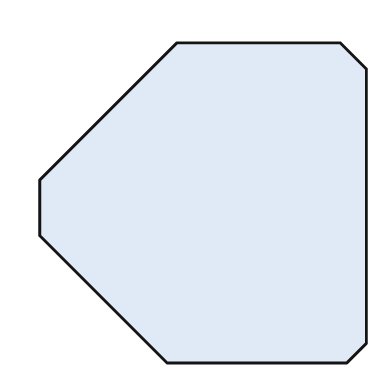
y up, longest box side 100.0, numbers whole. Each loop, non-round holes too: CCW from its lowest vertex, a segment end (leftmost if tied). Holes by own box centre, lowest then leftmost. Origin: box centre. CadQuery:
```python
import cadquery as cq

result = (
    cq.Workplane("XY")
    .moveTo(-11.0, -49.0)
    .lineTo(44.0, -49.0)
    .lineTo(50.0, -43.0)
    .lineTo(50.0, 41.0)
    .lineTo(42.0, 49.0)
    .lineTo(-8.0, 49.0)
    .lineTo(-50.0, 7.0)
    .lineTo(-50.0, -10.0)
    .close()
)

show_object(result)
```